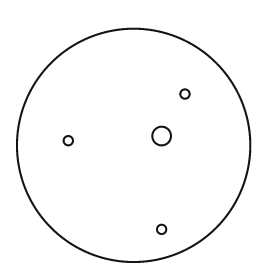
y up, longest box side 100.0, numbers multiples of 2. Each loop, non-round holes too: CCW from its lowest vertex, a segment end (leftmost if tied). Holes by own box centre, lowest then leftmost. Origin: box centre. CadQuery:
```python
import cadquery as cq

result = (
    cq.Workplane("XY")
    .moveTo(0.0, 0.0)
    .circle(50.0)
    .moveTo(12.0, -36.0)
    .circle(2.0)
    .moveTo(-28.0, 2.0)
    .circle(2.0)
    .moveTo(12.0, 4.0)
    .circle(4.0)
    .moveTo(22.0, 22.0)
    .circle(2.0)
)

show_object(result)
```